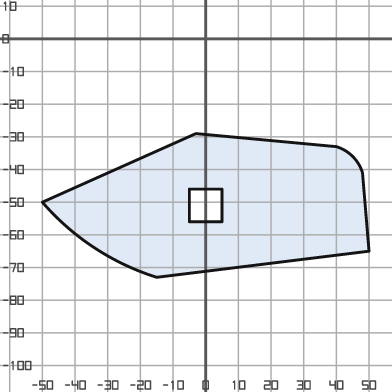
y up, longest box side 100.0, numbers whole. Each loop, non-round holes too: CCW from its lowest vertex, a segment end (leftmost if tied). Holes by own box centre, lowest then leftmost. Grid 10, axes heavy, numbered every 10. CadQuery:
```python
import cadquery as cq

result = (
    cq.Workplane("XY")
    .moveTo(-15.0, -73.0)
    .lineTo(50.0, -65.0)
    .lineTo(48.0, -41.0)
    .threePointArc((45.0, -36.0), (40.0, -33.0))
    .lineTo(-3.0, -29.0)
    .lineTo(-50.0, -50.0)
    .threePointArc((-34.0, -64.0), (-15.0, -73.0))
    .close()
    .moveTo(-5.0, -56.0)
    .lineTo(5.0, -56.0)
    .lineTo(5.0, -46.0)
    .lineTo(-5.0, -46.0)
    .close()
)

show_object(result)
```